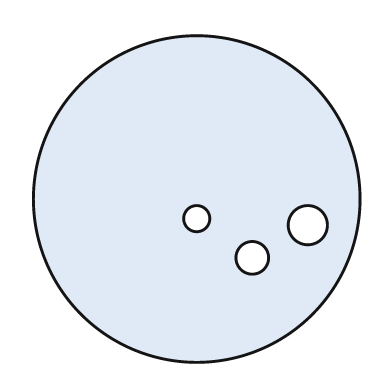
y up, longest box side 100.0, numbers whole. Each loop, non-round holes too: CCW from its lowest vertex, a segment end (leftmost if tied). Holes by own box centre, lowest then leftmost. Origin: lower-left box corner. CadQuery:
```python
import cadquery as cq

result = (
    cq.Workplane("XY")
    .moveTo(50.0, 50.0)
    .circle(50.0)
    .moveTo(67.0, 32.0)
    .circle(5.0)
    .moveTo(84.0, 42.0)
    .circle(6.0)
    .moveTo(50.0, 44.0)
    .circle(4.0)
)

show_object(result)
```